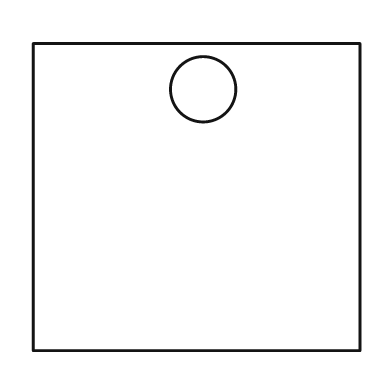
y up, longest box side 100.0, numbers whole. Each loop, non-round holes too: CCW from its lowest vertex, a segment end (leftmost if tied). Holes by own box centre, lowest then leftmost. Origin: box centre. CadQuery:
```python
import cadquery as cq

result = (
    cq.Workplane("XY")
    .moveTo(-50.0, -47.0)
    .lineTo(50.0, -47.0)
    .lineTo(50.0, 47.0)
    .lineTo(-50.0, 47.0)
    .close()
    .moveTo(2.0, 33.0)
    .circle(10.0)
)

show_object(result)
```